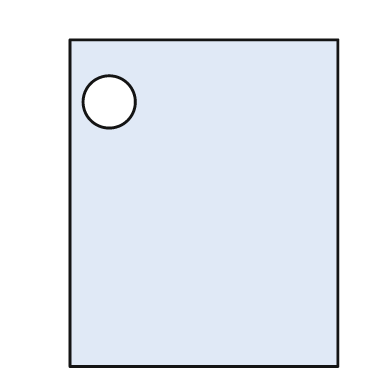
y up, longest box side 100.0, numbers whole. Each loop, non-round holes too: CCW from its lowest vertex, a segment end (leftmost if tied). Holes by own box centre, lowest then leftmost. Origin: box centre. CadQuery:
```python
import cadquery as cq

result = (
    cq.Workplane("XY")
    .moveTo(-41.0, -50.0)
    .lineTo(41.0, -50.0)
    .lineTo(41.0, 50.0)
    .lineTo(-41.0, 50.0)
    .close()
    .moveTo(-29.0, 31.0)
    .circle(8.0)
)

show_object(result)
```